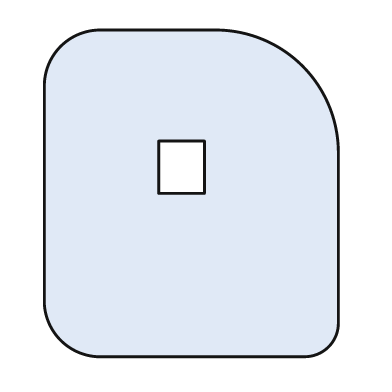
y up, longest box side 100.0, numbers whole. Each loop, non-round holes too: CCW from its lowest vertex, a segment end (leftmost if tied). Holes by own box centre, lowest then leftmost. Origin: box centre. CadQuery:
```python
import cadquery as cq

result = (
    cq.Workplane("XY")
    .moveTo(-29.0, -50.0)
    .lineTo(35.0, -50.0)
    .threePointArc((42.0, -47.0), (45.0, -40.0))
    .lineTo(45.0, 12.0)
    .threePointArc((34.0, 39.0), (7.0, 50.0))
    .lineTo(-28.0, 50.0)
    .threePointArc((-40.0, 45.0), (-45.0, 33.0))
    .lineTo(-45.0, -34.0)
    .threePointArc((-40.0, -45.0), (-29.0, -50.0))
    .close()
    .moveTo(-10.0, 0.0)
    .lineTo(4.0, 0.0)
    .lineTo(4.0, 16.0)
    .lineTo(-10.0, 16.0)
    .close()
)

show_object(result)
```